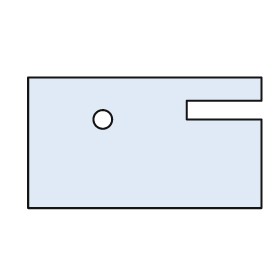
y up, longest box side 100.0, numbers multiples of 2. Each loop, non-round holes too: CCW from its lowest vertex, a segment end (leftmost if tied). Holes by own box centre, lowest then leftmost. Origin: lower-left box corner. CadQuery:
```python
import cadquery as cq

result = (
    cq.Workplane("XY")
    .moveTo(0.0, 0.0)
    .lineTo(100.0, 0.0)
    .lineTo(100.0, 38.0)
    .lineTo(68.0, 38.0)
    .lineTo(68.0, 46.0)
    .lineTo(100.0, 46.0)
    .lineTo(100.0, 56.0)
    .lineTo(0.0, 56.0)
    .close()
    .moveTo(32.0, 38.0)
    .circle(4.0)
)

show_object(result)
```